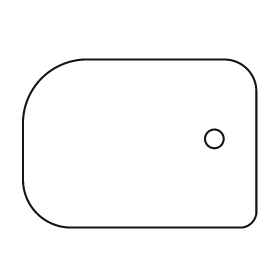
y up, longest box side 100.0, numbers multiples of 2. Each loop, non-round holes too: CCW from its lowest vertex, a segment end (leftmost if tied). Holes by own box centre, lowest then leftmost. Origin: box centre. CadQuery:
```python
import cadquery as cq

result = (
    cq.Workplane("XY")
    .moveTo(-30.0, -36.0)
    .lineTo(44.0, -36.0)
    .threePointArc((48.0, -34.0), (50.0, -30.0))
    .lineTo(50.0, 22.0)
    .threePointArc((46.0, 32.0), (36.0, 36.0))
    .lineTo(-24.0, 36.0)
    .threePointArc((-42.0, 28.0), (-50.0, 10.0))
    .lineTo(-50.0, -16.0)
    .threePointArc((-44.0, -30.0), (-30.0, -36.0))
    .close()
    .moveTo(32.0, 2.0)
    .circle(4.0)
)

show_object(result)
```